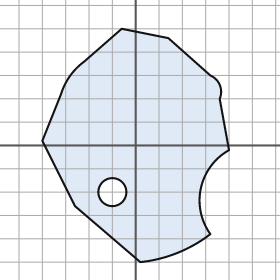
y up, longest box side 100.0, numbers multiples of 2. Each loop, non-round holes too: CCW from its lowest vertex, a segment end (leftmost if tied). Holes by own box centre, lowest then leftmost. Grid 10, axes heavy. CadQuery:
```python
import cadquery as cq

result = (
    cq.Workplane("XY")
    .moveTo(2.0, -50.0)
    .threePointArc((18.0, -46.0), (32.0, -38.0))
    .threePointArc((28.0, -18.0), (40.0, -2.0))
    .lineTo(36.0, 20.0)
    .threePointArc((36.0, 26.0), (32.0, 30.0))
    .lineTo(14.0, 46.0)
    .lineTo(-6.0, 50.0)
    .lineTo(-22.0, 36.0)
    .threePointArc((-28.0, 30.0), (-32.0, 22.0))
    .lineTo(-40.0, 2.0)
    .lineTo(-26.0, -26.0)
    .close()
    .moveTo(-10.0, -20.0)
    .circle(6.0)
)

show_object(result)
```